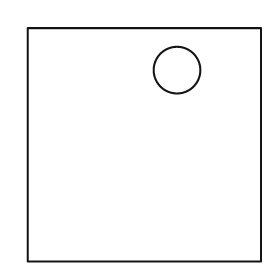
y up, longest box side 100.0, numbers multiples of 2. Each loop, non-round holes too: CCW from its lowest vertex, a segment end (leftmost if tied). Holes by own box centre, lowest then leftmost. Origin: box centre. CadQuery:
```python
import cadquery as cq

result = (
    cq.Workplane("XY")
    .moveTo(-50.0, -50.0)
    .lineTo(50.0, -50.0)
    .lineTo(50.0, 50.0)
    .lineTo(-50.0, 50.0)
    .close()
    .moveTo(14.0, 32.0)
    .circle(10.0)
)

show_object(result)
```